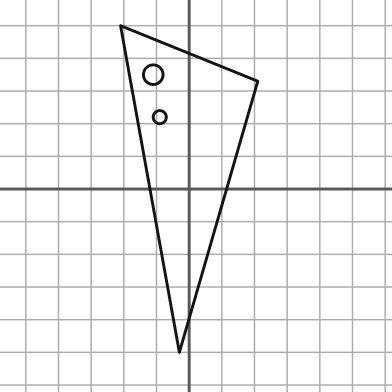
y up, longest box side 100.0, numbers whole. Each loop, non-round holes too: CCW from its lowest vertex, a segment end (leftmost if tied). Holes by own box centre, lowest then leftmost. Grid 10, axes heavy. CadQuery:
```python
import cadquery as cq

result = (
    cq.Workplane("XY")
    .moveTo(-3.0, -50.0)
    .lineTo(21.0, 33.0)
    .lineTo(-21.0, 50.0)
    .close()
    .moveTo(-9.0, 22.0)
    .circle(2.0)
    .moveTo(-11.0, 35.0)
    .circle(3.0)
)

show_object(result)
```